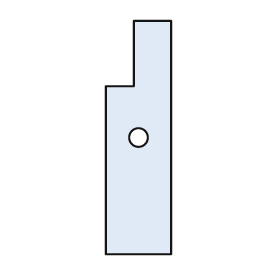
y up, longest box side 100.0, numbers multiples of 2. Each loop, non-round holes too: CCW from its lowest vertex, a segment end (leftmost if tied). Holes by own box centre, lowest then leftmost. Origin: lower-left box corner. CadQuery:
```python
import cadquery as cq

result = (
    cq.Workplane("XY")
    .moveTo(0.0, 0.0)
    .lineTo(28.0, 0.0)
    .lineTo(28.0, 100.0)
    .lineTo(12.0, 100.0)
    .lineTo(12.0, 72.0)
    .lineTo(0.0, 72.0)
    .close()
    .moveTo(14.0, 50.0)
    .circle(4.0)
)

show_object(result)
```